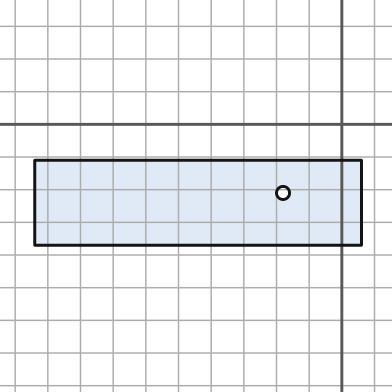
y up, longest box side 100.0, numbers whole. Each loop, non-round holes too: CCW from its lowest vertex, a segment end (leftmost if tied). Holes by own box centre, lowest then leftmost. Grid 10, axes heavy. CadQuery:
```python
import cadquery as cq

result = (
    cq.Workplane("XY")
    .moveTo(-94.0, -37.0)
    .lineTo(6.0, -37.0)
    .lineTo(6.0, -11.0)
    .lineTo(-94.0, -11.0)
    .close()
    .moveTo(-18.0, -21.0)
    .circle(2.0)
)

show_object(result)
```